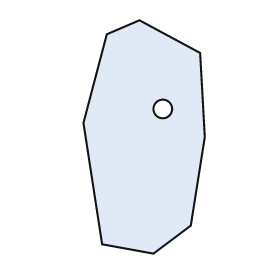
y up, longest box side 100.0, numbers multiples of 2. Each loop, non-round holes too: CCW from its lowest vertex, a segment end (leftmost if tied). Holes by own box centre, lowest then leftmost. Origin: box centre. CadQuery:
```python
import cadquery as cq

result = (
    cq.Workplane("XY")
    .moveTo(4.0, -50.0)
    .lineTo(20.0, -38.0)
    .lineTo(26.0, 0.0)
    .lineTo(24.0, 36.0)
    .lineTo(-2.0, 50.0)
    .lineTo(-16.0, 44.0)
    .lineTo(-26.0, 6.0)
    .lineTo(-18.0, -46.0)
    .close()
    .moveTo(8.0, 12.0)
    .circle(4.0)
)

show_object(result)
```